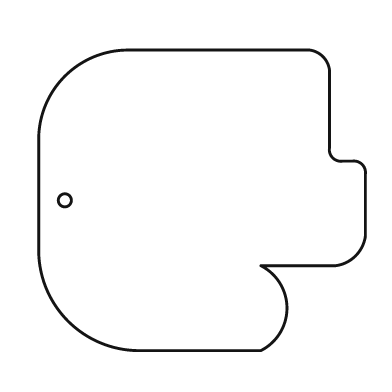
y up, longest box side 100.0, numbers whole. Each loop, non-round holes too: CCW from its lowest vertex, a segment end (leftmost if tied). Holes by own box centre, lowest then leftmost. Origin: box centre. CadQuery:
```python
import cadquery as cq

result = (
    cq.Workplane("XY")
    .moveTo(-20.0, -46.0)
    .lineTo(18.0, -46.0)
    .threePointArc((26.0, -33.0), (18.0, -20.0))
    .lineTo(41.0, -20.0)
    .threePointArc((47.0, -17.0), (50.0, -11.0))
    .lineTo(50.0, 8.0)
    .threePointArc((49.0, 11.0), (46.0, 12.0))
    .lineTo(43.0, 12.0)
    .threePointArc((40.0, 13.0), (39.0, 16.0))
    .lineTo(39.0, 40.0)
    .threePointArc((37.0, 44.0), (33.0, 46.0))
    .lineTo(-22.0, 46.0)
    .threePointArc((-42.0, 38.0), (-50.0, 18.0))
    .lineTo(-50.0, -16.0)
    .threePointArc((-41.0, -37.0), (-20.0, -46.0))
    .close()
    .moveTo(-42.0, 0.0)
    .circle(2.0)
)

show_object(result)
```